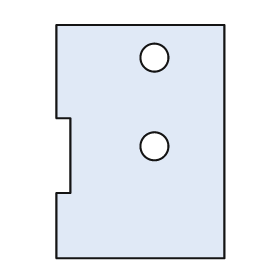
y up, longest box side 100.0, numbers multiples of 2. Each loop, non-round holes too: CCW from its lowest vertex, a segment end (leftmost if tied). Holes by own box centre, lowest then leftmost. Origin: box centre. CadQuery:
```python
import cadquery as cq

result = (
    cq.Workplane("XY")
    .moveTo(-36.0, -50.0)
    .lineTo(36.0, -50.0)
    .lineTo(36.0, 50.0)
    .lineTo(-36.0, 50.0)
    .lineTo(-36.0, 10.0)
    .lineTo(-30.0, 10.0)
    .lineTo(-30.0, -22.0)
    .lineTo(-36.0, -22.0)
    .close()
    .moveTo(6.0, -2.0)
    .circle(6.0)
    .moveTo(6.0, 36.0)
    .circle(6.0)
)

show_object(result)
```